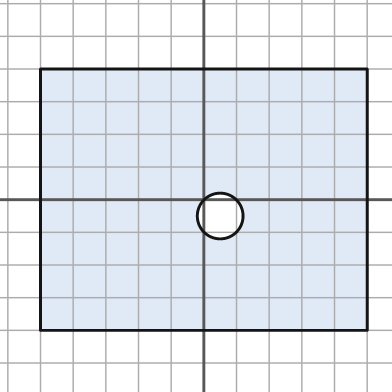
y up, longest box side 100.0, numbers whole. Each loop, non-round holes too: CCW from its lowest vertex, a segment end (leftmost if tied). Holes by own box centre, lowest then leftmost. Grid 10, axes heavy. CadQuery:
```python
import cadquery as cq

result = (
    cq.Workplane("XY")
    .moveTo(-50.0, -40.0)
    .lineTo(50.0, -40.0)
    .lineTo(50.0, 40.0)
    .lineTo(-50.0, 40.0)
    .close()
    .moveTo(5.0, -5.0)
    .circle(7.0)
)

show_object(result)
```